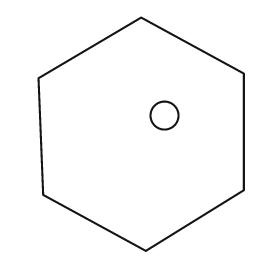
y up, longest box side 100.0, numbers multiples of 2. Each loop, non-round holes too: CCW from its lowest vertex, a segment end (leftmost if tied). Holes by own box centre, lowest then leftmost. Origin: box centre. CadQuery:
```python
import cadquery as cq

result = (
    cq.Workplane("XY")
    .moveTo(2.0, -50.0)
    .lineTo(44.0, -24.0)
    .lineTo(44.0, 26.0)
    .lineTo(0.0, 50.0)
    .lineTo(-44.0, 24.0)
    .lineTo(-42.0, -26.0)
    .close()
    .moveTo(10.0, 8.0)
    .circle(6.0)
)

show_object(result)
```